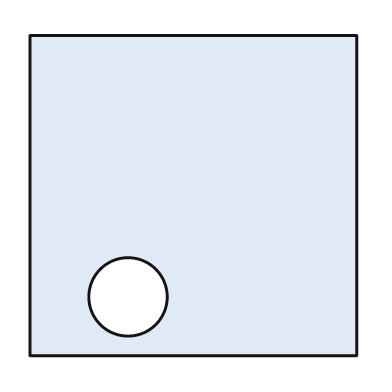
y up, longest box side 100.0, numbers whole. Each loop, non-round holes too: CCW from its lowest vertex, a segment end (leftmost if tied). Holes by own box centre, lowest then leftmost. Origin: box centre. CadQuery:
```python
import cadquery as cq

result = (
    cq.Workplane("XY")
    .moveTo(-50.0, -49.0)
    .lineTo(50.0, -49.0)
    .lineTo(50.0, 49.0)
    .lineTo(-50.0, 49.0)
    .close()
    .moveTo(-20.0, -31.0)
    .circle(12.0)
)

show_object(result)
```